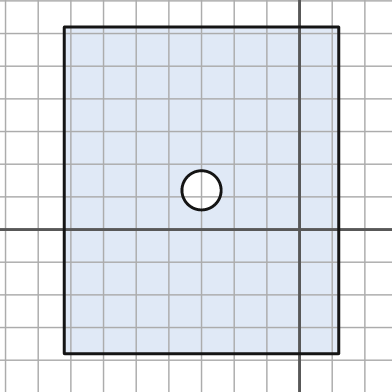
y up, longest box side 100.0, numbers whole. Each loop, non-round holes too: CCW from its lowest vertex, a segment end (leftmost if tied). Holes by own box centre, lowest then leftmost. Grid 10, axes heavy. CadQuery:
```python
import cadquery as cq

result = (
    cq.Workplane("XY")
    .moveTo(-72.0, -38.0)
    .lineTo(12.0, -38.0)
    .lineTo(12.0, 62.0)
    .lineTo(-72.0, 62.0)
    .close()
    .moveTo(-30.0, 12.0)
    .circle(6.0)
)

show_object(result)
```